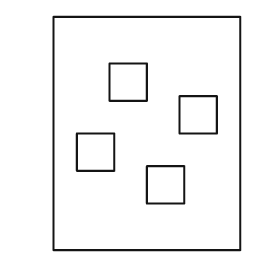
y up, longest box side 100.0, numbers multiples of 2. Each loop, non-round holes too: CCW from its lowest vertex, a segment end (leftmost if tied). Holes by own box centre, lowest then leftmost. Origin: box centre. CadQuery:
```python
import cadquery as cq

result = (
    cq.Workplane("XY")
    .moveTo(-40.0, -50.0)
    .lineTo(40.0, -50.0)
    .lineTo(40.0, 50.0)
    .lineTo(-40.0, 50.0)
    .close()
    .moveTo(0.0, -30.0)
    .lineTo(16.0, -30.0)
    .lineTo(16.0, -14.0)
    .lineTo(0.0, -14.0)
    .close()
    .moveTo(-30.0, -16.0)
    .lineTo(-14.0, -16.0)
    .lineTo(-14.0, 0.0)
    .lineTo(-30.0, 0.0)
    .close()
    .moveTo(14.0, 0.0)
    .lineTo(30.0, 0.0)
    .lineTo(30.0, 16.0)
    .lineTo(14.0, 16.0)
    .close()
    .moveTo(-16.0, 14.0)
    .lineTo(0.0, 14.0)
    .lineTo(0.0, 30.0)
    .lineTo(-16.0, 30.0)
    .close()
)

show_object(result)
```